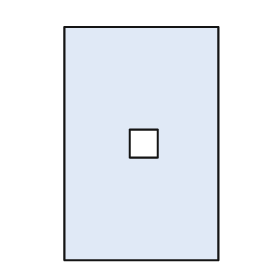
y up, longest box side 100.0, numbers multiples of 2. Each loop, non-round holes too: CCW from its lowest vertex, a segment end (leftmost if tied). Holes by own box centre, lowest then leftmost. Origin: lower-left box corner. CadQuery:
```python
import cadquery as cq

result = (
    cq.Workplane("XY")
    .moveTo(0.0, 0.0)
    .lineTo(66.0, 0.0)
    .lineTo(66.0, 100.0)
    .lineTo(0.0, 100.0)
    .close()
    .moveTo(28.0, 44.0)
    .lineTo(40.0, 44.0)
    .lineTo(40.0, 56.0)
    .lineTo(28.0, 56.0)
    .close()
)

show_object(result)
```